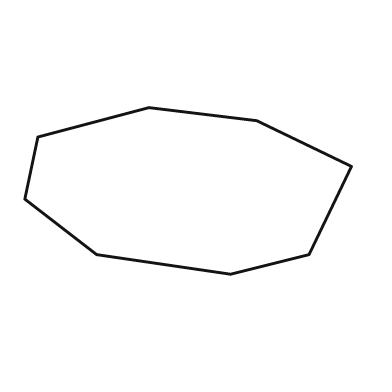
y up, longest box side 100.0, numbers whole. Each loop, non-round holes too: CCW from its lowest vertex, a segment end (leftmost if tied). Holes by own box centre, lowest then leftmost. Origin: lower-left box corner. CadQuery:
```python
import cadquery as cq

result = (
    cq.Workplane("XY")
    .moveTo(63.0, 0.0)
    .lineTo(87.0, 6.0)
    .lineTo(100.0, 33.0)
    .lineTo(71.0, 47.0)
    .lineTo(38.0, 51.0)
    .lineTo(4.0, 42.0)
    .lineTo(0.0, 23.0)
    .lineTo(22.0, 6.0)
    .close()
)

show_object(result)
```